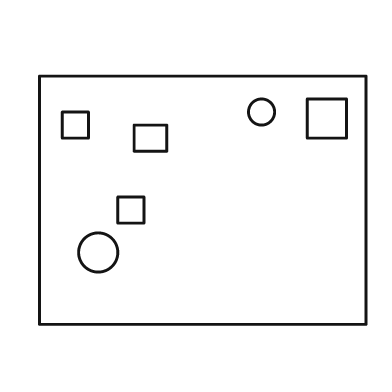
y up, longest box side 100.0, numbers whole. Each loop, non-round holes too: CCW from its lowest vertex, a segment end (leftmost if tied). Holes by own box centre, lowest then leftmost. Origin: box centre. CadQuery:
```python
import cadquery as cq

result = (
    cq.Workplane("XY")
    .moveTo(-50.0, -38.0)
    .lineTo(50.0, -38.0)
    .lineTo(50.0, 38.0)
    .lineTo(-50.0, 38.0)
    .close()
    .moveTo(-32.0, -16.0)
    .circle(6.0)
    .moveTo(-26.0, -7.0)
    .lineTo(-18.0, -7.0)
    .lineTo(-18.0, 1.0)
    .lineTo(-26.0, 1.0)
    .close()
    .moveTo(-21.0, 15.0)
    .lineTo(-11.0, 15.0)
    .lineTo(-11.0, 23.0)
    .lineTo(-21.0, 23.0)
    .close()
    .moveTo(-43.0, 19.0)
    .lineTo(-35.0, 19.0)
    .lineTo(-35.0, 27.0)
    .lineTo(-43.0, 27.0)
    .close()
    .moveTo(32.0, 19.0)
    .lineTo(44.0, 19.0)
    .lineTo(44.0, 31.0)
    .lineTo(32.0, 31.0)
    .close()
    .moveTo(18.0, 27.0)
    .circle(4.0)
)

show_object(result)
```